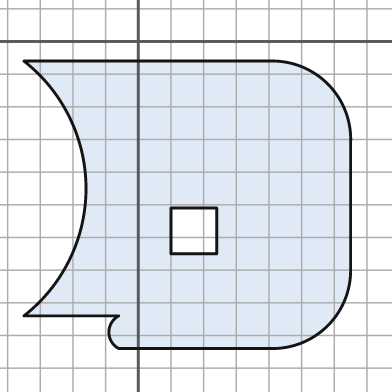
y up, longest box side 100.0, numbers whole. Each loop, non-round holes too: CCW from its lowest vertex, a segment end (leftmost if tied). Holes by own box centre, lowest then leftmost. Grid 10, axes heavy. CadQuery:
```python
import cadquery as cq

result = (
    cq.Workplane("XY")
    .moveTo(-6.0, -94.0)
    .lineTo(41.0, -94.0)
    .threePointArc((58.0, -87.0), (65.0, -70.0))
    .lineTo(65.0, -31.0)
    .threePointArc((58.0, -13.0), (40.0, -6.0))
    .lineTo(-35.0, -6.0)
    .threePointArc((-16.0, -45.0), (-35.0, -84.0))
    .lineTo(-6.0, -84.0)
    .threePointArc((-9.0, -89.0), (-6.0, -94.0))
    .close()
    .moveTo(10.0, -65.0)
    .lineTo(24.0, -65.0)
    .lineTo(24.0, -51.0)
    .lineTo(10.0, -51.0)
    .close()
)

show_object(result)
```